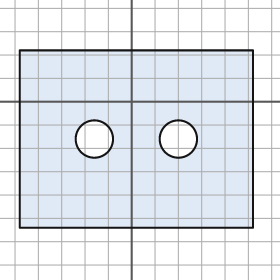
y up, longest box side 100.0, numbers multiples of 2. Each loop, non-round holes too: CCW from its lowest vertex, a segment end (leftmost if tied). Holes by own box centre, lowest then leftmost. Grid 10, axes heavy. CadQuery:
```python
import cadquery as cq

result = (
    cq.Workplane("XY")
    .moveTo(-48.0, -54.0)
    .lineTo(52.0, -54.0)
    .lineTo(52.0, 22.0)
    .lineTo(-48.0, 22.0)
    .close()
    .moveTo(-16.0, -16.0)
    .circle(8.0)
    .moveTo(20.0, -16.0)
    .circle(8.0)
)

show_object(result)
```